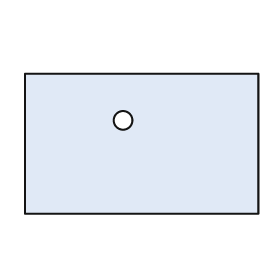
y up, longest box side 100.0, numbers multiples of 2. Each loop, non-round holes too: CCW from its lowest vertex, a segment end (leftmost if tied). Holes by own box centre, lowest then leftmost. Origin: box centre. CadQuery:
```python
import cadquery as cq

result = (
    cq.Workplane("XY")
    .moveTo(-50.0, -30.0)
    .lineTo(50.0, -30.0)
    .lineTo(50.0, 30.0)
    .lineTo(-50.0, 30.0)
    .close()
    .moveTo(-8.0, 10.0)
    .circle(4.0)
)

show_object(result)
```